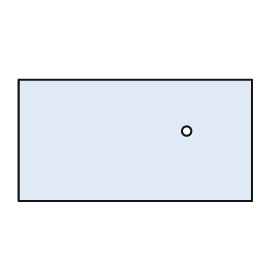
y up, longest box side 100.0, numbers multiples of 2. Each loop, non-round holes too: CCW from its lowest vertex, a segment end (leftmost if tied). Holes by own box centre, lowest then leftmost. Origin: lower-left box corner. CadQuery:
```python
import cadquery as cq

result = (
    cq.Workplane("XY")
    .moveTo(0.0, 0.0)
    .lineTo(100.0, 0.0)
    .lineTo(100.0, 52.0)
    .lineTo(0.0, 52.0)
    .close()
    .moveTo(72.0, 30.0)
    .circle(2.0)
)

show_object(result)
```